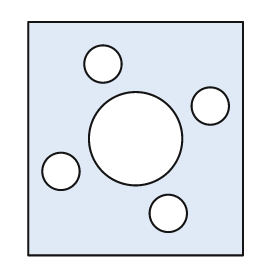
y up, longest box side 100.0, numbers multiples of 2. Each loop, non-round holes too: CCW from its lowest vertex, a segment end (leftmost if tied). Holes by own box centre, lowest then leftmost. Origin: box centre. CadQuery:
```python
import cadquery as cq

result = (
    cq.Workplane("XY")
    .moveTo(-46.0, -50.0)
    .lineTo(46.0, -50.0)
    .lineTo(46.0, 50.0)
    .lineTo(-46.0, 50.0)
    .close()
    .moveTo(14.0, -32.0)
    .circle(8.0)
    .moveTo(-32.0, -14.0)
    .circle(8.0)
    .moveTo(0.0, 0.0)
    .circle(20.0)
    .moveTo(32.0, 14.0)
    .circle(8.0)
    .moveTo(-14.0, 32.0)
    .circle(8.0)
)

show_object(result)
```